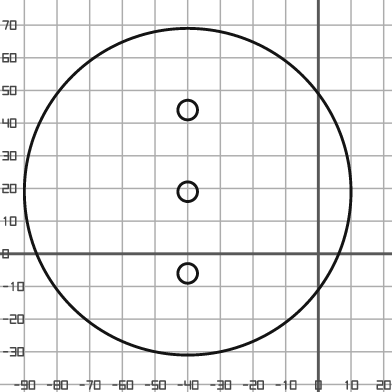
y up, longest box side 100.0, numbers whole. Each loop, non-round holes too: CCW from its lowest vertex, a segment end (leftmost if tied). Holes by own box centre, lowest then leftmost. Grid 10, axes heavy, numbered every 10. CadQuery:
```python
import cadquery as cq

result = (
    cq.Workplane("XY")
    .moveTo(-40.0, 19.0)
    .circle(50.0)
    .moveTo(-40.0, -6.0)
    .circle(3.0)
    .moveTo(-40.0, 19.0)
    .circle(3.0)
    .moveTo(-40.0, 44.0)
    .circle(3.0)
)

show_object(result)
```